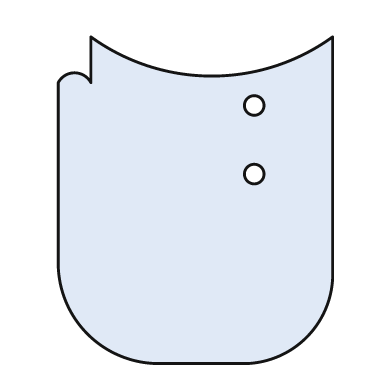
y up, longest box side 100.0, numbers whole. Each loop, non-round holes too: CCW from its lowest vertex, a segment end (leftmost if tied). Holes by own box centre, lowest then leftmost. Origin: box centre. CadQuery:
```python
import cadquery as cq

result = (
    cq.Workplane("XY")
    .moveTo(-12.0, -50.0)
    .lineTo(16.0, -50.0)
    .threePointArc((34.0, -42.0), (42.0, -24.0))
    .lineTo(42.0, 50.0)
    .threePointArc((5.0, 38.0), (-32.0, 50.0))
    .lineTo(-32.0, 36.0)
    .threePointArc((-37.0, 39.0), (-42.0, 36.0))
    .lineTo(-42.0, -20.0)
    .threePointArc((-33.0, -41.0), (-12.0, -50.0))
    .close()
    .moveTo(18.0, 8.0)
    .circle(3.0)
    .moveTo(18.0, 29.0)
    .circle(3.0)
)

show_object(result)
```